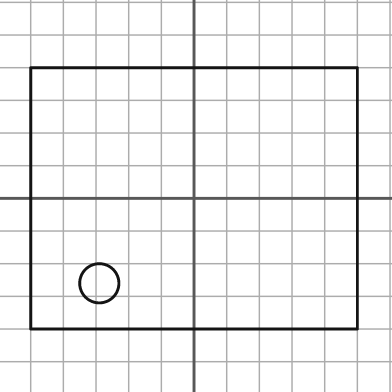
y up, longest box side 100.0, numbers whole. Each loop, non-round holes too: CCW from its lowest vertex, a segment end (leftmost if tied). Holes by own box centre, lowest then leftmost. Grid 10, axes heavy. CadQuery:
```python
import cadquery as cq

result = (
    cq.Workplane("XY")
    .moveTo(-50.0, -40.0)
    .lineTo(50.0, -40.0)
    .lineTo(50.0, 40.0)
    .lineTo(-50.0, 40.0)
    .close()
    .moveTo(-29.0, -26.0)
    .circle(6.0)
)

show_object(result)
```